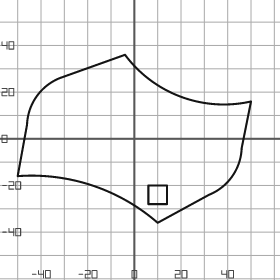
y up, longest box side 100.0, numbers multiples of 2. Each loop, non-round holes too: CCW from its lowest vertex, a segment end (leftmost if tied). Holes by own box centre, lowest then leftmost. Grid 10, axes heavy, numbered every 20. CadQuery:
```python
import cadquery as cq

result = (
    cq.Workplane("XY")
    .moveTo(10.0, -36.0)
    .lineTo(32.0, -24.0)
    .threePointArc((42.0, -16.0), (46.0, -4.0))
    .lineTo(50.0, 16.0)
    .threePointArc((20.0, 18.0), (-4.0, 36.0))
    .lineTo(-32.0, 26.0)
    .threePointArc((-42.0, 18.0), (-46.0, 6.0))
    .lineTo(-50.0, -16.0)
    .threePointArc((-18.0, -20.0), (10.0, -36.0))
    .close()
    .moveTo(6.0, -28.0)
    .lineTo(14.0, -28.0)
    .lineTo(14.0, -20.0)
    .lineTo(6.0, -20.0)
    .close()
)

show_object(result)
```